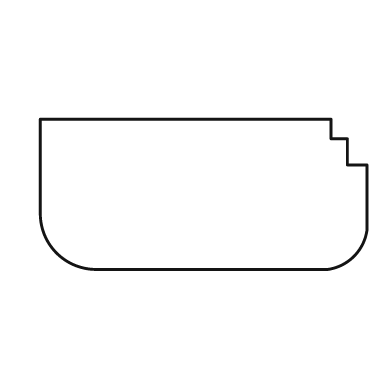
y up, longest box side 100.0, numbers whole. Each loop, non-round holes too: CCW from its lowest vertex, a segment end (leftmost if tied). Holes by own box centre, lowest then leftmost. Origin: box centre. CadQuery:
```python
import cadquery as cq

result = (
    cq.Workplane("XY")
    .moveTo(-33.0, -23.0)
    .lineTo(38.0, -23.0)
    .threePointArc((46.0, -19.0), (50.0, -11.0))
    .lineTo(50.0, 9.0)
    .lineTo(44.0, 9.0)
    .lineTo(44.0, 17.0)
    .lineTo(39.0, 17.0)
    .lineTo(39.0, 23.0)
    .lineTo(-50.0, 23.0)
    .lineTo(-50.0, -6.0)
    .threePointArc((-45.0, -18.0), (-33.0, -23.0))
    .close()
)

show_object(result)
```